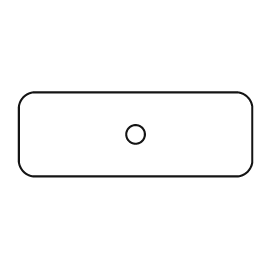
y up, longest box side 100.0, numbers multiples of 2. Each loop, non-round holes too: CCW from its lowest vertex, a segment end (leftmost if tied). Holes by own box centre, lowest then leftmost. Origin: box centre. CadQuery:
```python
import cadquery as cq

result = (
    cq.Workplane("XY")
    .moveTo(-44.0, -18.0)
    .lineTo(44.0, -18.0)
    .threePointArc((48.0, -16.0), (50.0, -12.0))
    .lineTo(50.0, 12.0)
    .threePointArc((48.0, 16.0), (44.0, 18.0))
    .lineTo(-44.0, 18.0)
    .threePointArc((-48.0, 16.0), (-50.0, 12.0))
    .lineTo(-50.0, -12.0)
    .threePointArc((-48.0, -16.0), (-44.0, -18.0))
    .close()
    .moveTo(0.0, 0.0)
    .circle(4.0)
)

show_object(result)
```